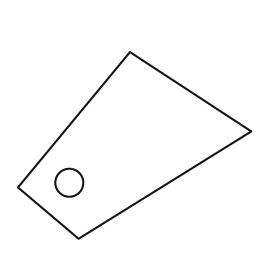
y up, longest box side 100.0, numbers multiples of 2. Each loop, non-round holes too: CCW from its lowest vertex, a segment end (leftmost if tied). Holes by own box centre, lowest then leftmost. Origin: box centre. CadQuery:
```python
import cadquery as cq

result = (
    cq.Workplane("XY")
    .moveTo(-24.0, -40.0)
    .lineTo(50.0, 6.0)
    .lineTo(-2.0, 40.0)
    .lineTo(-50.0, -18.0)
    .close()
    .moveTo(-28.0, -16.0)
    .circle(6.0)
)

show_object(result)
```